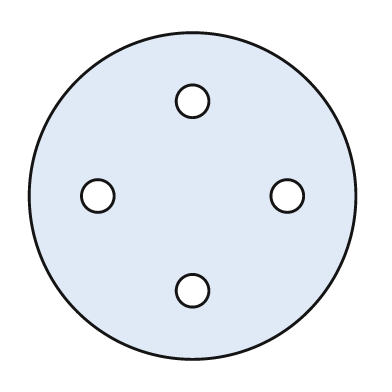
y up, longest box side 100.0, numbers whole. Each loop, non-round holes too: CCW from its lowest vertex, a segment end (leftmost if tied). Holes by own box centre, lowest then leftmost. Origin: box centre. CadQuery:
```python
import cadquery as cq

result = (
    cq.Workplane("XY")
    .moveTo(0.0, 0.0)
    .circle(50.0)
    .moveTo(0.0, -29.0)
    .circle(5.0)
    .moveTo(-29.0, 0.0)
    .circle(5.0)
    .moveTo(29.0, 0.0)
    .circle(5.0)
    .moveTo(0.0, 29.0)
    .circle(5.0)
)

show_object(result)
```